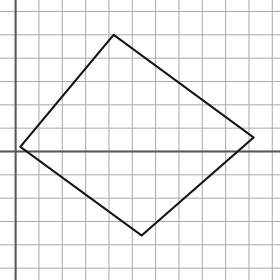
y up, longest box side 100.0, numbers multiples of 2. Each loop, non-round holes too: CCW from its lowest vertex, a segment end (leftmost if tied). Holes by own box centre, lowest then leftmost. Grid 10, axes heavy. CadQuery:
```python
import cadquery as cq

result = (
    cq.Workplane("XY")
    .moveTo(54.0, -36.0)
    .lineTo(102.0, 6.0)
    .lineTo(42.0, 50.0)
    .lineTo(2.0, 2.0)
    .close()
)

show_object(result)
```